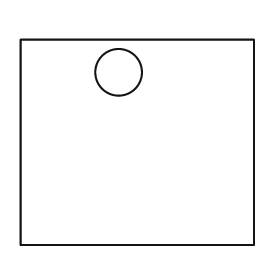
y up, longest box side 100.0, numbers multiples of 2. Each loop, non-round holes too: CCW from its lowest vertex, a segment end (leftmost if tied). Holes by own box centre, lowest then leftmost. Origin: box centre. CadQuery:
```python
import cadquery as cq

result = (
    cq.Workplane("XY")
    .moveTo(-50.0, -44.0)
    .lineTo(50.0, -44.0)
    .lineTo(50.0, 44.0)
    .lineTo(-50.0, 44.0)
    .close()
    .moveTo(-8.0, 30.0)
    .circle(10.0)
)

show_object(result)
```